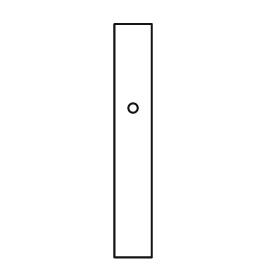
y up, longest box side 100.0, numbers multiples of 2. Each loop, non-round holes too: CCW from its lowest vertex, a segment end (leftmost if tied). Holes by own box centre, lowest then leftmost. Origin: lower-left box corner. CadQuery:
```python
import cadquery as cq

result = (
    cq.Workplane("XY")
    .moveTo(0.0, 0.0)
    .lineTo(16.0, 0.0)
    .lineTo(16.0, 100.0)
    .lineTo(0.0, 100.0)
    .close()
    .moveTo(8.0, 64.0)
    .circle(2.0)
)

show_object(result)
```